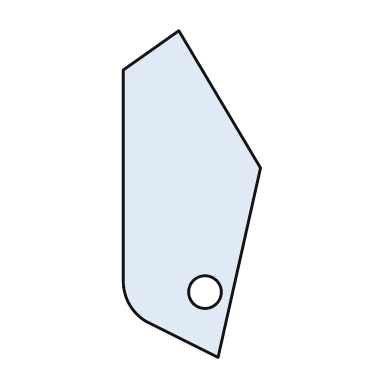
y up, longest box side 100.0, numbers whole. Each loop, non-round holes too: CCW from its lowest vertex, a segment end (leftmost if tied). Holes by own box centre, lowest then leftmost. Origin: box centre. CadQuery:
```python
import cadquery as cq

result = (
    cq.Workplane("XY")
    .moveTo(8.0, -50.0)
    .lineTo(21.0, 8.0)
    .lineTo(-4.0, 50.0)
    .lineTo(-21.0, 38.0)
    .lineTo(-21.0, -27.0)
    .threePointArc((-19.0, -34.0), (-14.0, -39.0))
    .close()
    .moveTo(4.0, -30.0)
    .circle(5.0)
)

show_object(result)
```